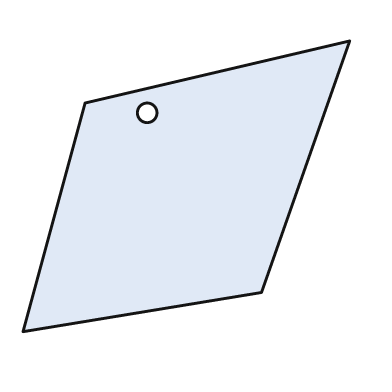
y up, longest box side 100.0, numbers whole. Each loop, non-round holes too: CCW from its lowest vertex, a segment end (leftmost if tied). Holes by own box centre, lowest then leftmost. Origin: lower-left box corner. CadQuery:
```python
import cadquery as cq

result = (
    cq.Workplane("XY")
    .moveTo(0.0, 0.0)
    .lineTo(73.0, 12.0)
    .lineTo(100.0, 89.0)
    .lineTo(19.0, 70.0)
    .close()
    .moveTo(38.0, 67.0)
    .circle(3.0)
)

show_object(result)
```